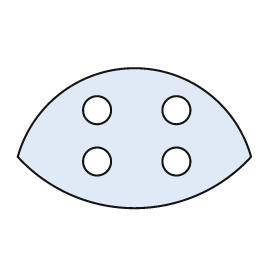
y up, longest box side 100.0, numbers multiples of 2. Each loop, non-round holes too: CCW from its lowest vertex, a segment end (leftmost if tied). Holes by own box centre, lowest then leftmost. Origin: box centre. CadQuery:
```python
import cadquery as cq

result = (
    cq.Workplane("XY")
    .moveTo(-50.0, -8.0)
    .threePointArc((0.0, -30.0), (50.0, -8.0))
    .threePointArc((0.0, 30.0), (-50.0, -8.0))
    .close()
    .moveTo(-16.0, -10.0)
    .circle(6.0)
    .moveTo(18.0, -10.0)
    .circle(6.0)
    .moveTo(-16.0, 12.0)
    .circle(6.0)
    .moveTo(18.0, 12.0)
    .circle(6.0)
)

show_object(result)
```